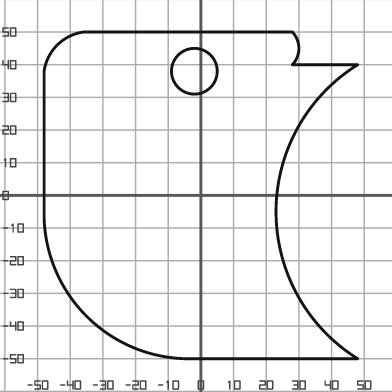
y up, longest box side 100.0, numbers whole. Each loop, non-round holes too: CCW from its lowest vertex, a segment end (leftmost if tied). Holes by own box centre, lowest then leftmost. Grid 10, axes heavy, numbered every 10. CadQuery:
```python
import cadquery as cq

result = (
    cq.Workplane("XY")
    .moveTo(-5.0, -50.0)
    .lineTo(48.0, -50.0)
    .threePointArc((23.0, -5.0), (48.0, 40.0))
    .lineTo(28.0, 40.0)
    .threePointArc((30.0, 45.0), (28.0, 50.0))
    .lineTo(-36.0, 50.0)
    .threePointArc((-44.0, 46.0), (-48.0, 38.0))
    .lineTo(-48.0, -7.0)
    .threePointArc((-35.0, -37.0), (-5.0, -50.0))
    .close()
    .moveTo(-2.0, 38.0)
    .circle(7.0)
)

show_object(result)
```